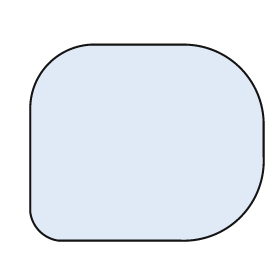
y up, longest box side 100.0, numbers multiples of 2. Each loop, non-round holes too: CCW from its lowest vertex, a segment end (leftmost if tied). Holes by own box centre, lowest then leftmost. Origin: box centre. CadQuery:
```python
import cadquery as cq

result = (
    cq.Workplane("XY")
    .moveTo(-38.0, -42.0)
    .lineTo(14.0, -42.0)
    .threePointArc((40.0, -32.0), (50.0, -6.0))
    .lineTo(50.0, 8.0)
    .threePointArc((40.0, 32.0), (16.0, 42.0))
    .lineTo(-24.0, 42.0)
    .threePointArc((-42.0, 34.0), (-50.0, 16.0))
    .lineTo(-50.0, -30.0)
    .threePointArc((-46.0, -38.0), (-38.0, -42.0))
    .close()
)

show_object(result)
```